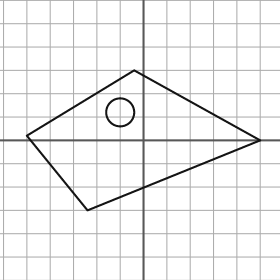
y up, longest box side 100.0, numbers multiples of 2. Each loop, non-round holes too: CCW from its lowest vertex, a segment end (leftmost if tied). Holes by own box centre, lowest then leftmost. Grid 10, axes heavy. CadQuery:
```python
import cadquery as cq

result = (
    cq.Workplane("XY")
    .moveTo(-24.0, -30.0)
    .lineTo(50.0, 0.0)
    .lineTo(-4.0, 30.0)
    .lineTo(-50.0, 2.0)
    .close()
    .moveTo(-10.0, 12.0)
    .circle(6.0)
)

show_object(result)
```